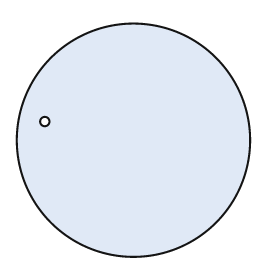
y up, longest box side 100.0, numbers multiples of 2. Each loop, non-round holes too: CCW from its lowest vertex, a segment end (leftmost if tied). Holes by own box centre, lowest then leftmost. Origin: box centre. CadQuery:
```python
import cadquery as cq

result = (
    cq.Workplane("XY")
    .moveTo(0.0, 0.0)
    .circle(50.0)
    .moveTo(-38.0, 8.0)
    .circle(2.0)
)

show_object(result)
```